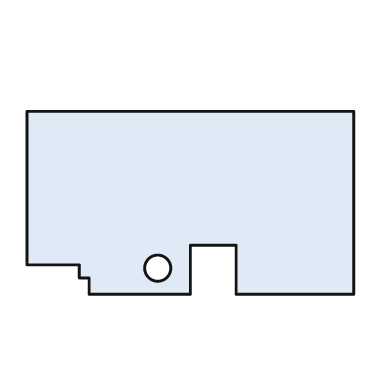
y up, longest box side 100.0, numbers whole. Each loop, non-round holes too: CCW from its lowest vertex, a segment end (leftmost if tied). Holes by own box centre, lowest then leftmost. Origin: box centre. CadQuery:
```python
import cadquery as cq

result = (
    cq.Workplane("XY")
    .moveTo(-31.0, -28.0)
    .lineTo(0.0, -28.0)
    .lineTo(0.0, -13.0)
    .lineTo(14.0, -13.0)
    .lineTo(14.0, -28.0)
    .lineTo(50.0, -28.0)
    .lineTo(50.0, 28.0)
    .lineTo(-50.0, 28.0)
    .lineTo(-50.0, -19.0)
    .lineTo(-34.0, -19.0)
    .lineTo(-34.0, -23.0)
    .lineTo(-31.0, -23.0)
    .close()
    .moveTo(-10.0, -20.0)
    .circle(4.0)
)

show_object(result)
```